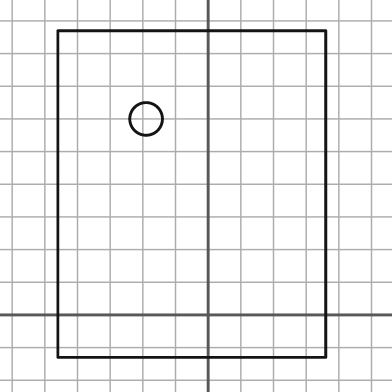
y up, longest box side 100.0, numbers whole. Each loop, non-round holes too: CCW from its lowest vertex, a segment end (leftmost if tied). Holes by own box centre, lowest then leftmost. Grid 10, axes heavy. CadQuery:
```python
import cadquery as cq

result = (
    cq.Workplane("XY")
    .moveTo(-46.0, -13.0)
    .lineTo(36.0, -13.0)
    .lineTo(36.0, 87.0)
    .lineTo(-46.0, 87.0)
    .close()
    .moveTo(-19.0, 60.0)
    .circle(5.0)
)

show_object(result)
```